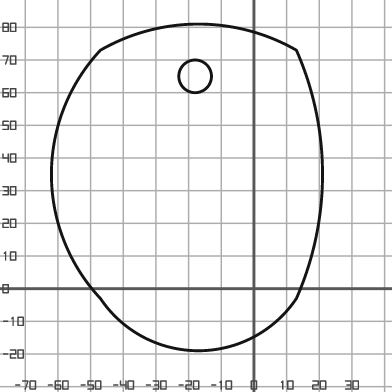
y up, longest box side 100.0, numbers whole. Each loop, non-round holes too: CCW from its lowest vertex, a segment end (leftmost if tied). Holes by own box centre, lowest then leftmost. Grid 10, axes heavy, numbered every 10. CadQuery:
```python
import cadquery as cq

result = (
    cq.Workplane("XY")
    .moveTo(-47.0, -3.0)
    .threePointArc((-17.0, -19.0), (13.0, -3.0))
    .threePointArc((21.0, 35.0), (13.0, 73.0))
    .threePointArc((-17.0, 81.0), (-47.0, 73.0))
    .threePointArc((-62.0, 35.0), (-47.0, -3.0))
    .close()
    .moveTo(-18.0, 65.0)
    .circle(5.0)
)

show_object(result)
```